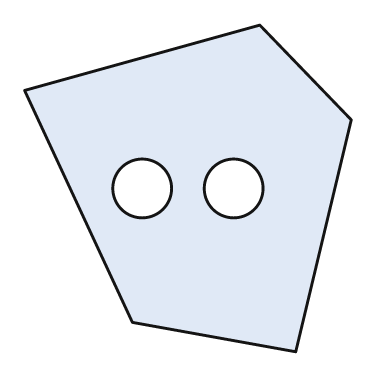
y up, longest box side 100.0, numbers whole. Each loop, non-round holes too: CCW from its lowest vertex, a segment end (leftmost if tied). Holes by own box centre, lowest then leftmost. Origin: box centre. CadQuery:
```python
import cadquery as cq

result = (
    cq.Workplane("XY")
    .moveTo(33.0, -50.0)
    .lineTo(50.0, 21.0)
    .lineTo(22.0, 50.0)
    .lineTo(-50.0, 30.0)
    .lineTo(-17.0, -41.0)
    .close()
    .moveTo(-14.0, 0.0)
    .circle(9.0)
    .moveTo(14.0, 0.0)
    .circle(9.0)
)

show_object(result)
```